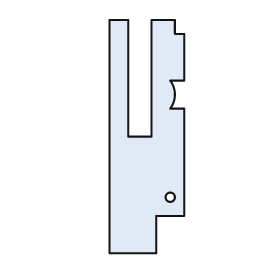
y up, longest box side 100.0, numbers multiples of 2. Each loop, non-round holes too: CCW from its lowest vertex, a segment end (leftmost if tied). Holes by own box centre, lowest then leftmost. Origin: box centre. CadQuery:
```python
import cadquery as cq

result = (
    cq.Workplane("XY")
    .moveTo(-16.0, -50.0)
    .lineTo(4.0, -50.0)
    .lineTo(4.0, -34.0)
    .lineTo(16.0, -34.0)
    .lineTo(16.0, 12.0)
    .lineTo(10.0, 12.0)
    .threePointArc((12.0, 18.0), (10.0, 24.0))
    .lineTo(16.0, 24.0)
    .lineTo(16.0, 44.0)
    .lineTo(12.0, 44.0)
    .lineTo(12.0, 50.0)
    .lineTo(2.0, 50.0)
    .lineTo(2.0, 0.0)
    .lineTo(-8.0, 0.0)
    .lineTo(-8.0, 50.0)
    .lineTo(-16.0, 50.0)
    .close()
    .moveTo(10.0, -26.0)
    .circle(2.0)
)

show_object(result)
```